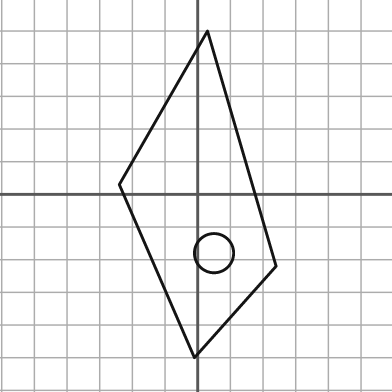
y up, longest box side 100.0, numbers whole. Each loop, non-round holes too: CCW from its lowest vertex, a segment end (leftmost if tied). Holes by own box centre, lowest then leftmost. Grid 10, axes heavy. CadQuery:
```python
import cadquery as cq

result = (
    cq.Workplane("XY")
    .moveTo(-1.0, -50.0)
    .lineTo(24.0, -22.0)
    .lineTo(3.0, 50.0)
    .lineTo(-24.0, 3.0)
    .close()
    .moveTo(5.0, -18.0)
    .circle(6.0)
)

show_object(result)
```